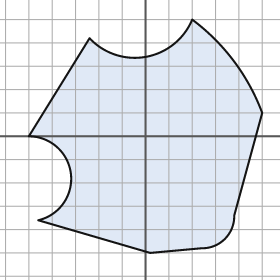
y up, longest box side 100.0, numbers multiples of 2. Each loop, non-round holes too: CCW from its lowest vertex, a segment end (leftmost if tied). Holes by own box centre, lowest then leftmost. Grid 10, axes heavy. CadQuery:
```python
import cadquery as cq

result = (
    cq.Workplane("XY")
    .moveTo(2.0, -50.0)
    .lineTo(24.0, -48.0)
    .threePointArc((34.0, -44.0), (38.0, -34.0))
    .lineTo(50.0, 10.0)
    .threePointArc((38.0, 32.0), (20.0, 50.0))
    .threePointArc((0.0, 34.0), (-24.0, 42.0))
    .lineTo(-50.0, 0.0)
    .threePointArc((-32.0, -16.0), (-46.0, -36.0))
    .close()
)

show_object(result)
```